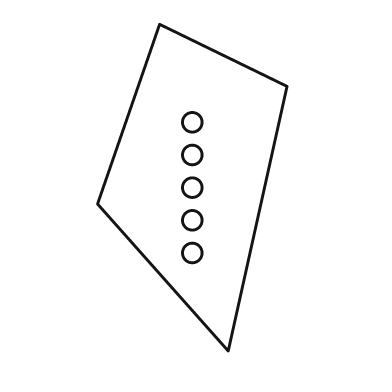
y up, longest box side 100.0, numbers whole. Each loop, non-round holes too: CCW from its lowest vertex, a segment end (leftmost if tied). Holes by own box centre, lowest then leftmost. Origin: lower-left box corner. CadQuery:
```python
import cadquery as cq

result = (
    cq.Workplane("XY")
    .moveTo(40.0, 0.0)
    .lineTo(58.0, 81.0)
    .lineTo(19.0, 100.0)
    .lineTo(0.0, 45.0)
    .close()
    .moveTo(29.0, 30.0)
    .circle(3.0)
    .moveTo(29.0, 40.0)
    .circle(3.0)
    .moveTo(29.0, 50.0)
    .circle(3.0)
    .moveTo(29.0, 60.0)
    .circle(3.0)
    .moveTo(29.0, 70.0)
    .circle(3.0)
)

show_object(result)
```